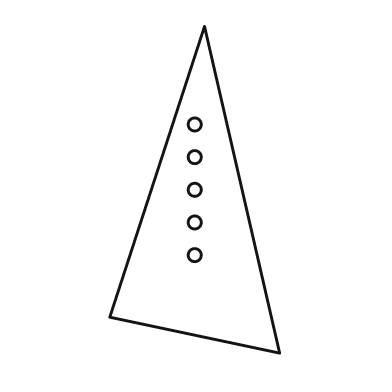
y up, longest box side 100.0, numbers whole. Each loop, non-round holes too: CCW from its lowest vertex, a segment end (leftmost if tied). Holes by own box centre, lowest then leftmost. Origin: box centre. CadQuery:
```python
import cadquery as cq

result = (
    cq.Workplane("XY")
    .moveTo(26.0, -50.0)
    .lineTo(3.0, 50.0)
    .lineTo(-26.0, -39.0)
    .close()
    .moveTo(0.0, -20.0)
    .circle(2.0)
    .moveTo(0.0, -10.0)
    .circle(2.0)
    .moveTo(0.0, 0.0)
    .circle(2.0)
    .moveTo(0.0, 10.0)
    .circle(2.0)
    .moveTo(0.0, 20.0)
    .circle(2.0)
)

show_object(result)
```